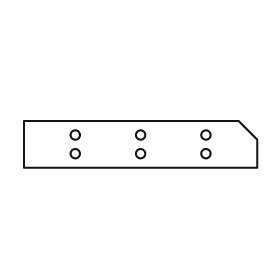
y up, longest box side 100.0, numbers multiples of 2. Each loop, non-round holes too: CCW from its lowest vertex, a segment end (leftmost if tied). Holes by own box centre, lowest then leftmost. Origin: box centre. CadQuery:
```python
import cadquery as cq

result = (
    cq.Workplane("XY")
    .moveTo(-50.0, -10.0)
    .lineTo(50.0, -10.0)
    .lineTo(50.0, 2.0)
    .lineTo(42.0, 10.0)
    .lineTo(-50.0, 10.0)
    .close()
    .moveTo(-28.0, -4.0)
    .circle(2.0)
    .moveTo(0.0, -4.0)
    .circle(2.0)
    .moveTo(28.0, -4.0)
    .circle(2.0)
    .moveTo(-28.0, 4.0)
    .circle(2.0)
    .moveTo(0.0, 4.0)
    .circle(2.0)
    .moveTo(28.0, 4.0)
    .circle(2.0)
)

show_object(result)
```